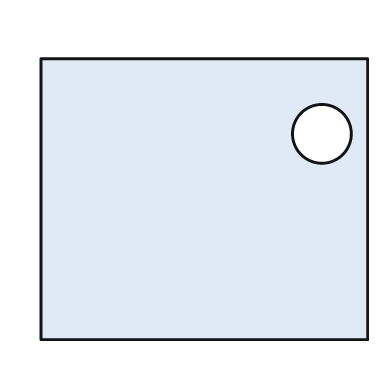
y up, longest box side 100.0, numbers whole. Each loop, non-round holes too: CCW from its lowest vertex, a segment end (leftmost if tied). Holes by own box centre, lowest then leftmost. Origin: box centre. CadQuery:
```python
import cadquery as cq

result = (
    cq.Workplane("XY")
    .moveTo(-50.0, -43.0)
    .lineTo(50.0, -43.0)
    .lineTo(50.0, 43.0)
    .lineTo(-50.0, 43.0)
    .close()
    .moveTo(36.0, 20.0)
    .circle(9.0)
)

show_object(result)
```